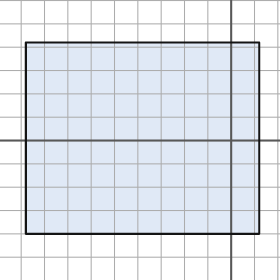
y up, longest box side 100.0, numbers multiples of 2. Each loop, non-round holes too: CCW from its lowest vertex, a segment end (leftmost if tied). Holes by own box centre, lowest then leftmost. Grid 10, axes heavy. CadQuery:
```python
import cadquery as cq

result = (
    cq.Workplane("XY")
    .moveTo(-88.0, -40.0)
    .lineTo(12.0, -40.0)
    .lineTo(12.0, 42.0)
    .lineTo(-88.0, 42.0)
    .close()
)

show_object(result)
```